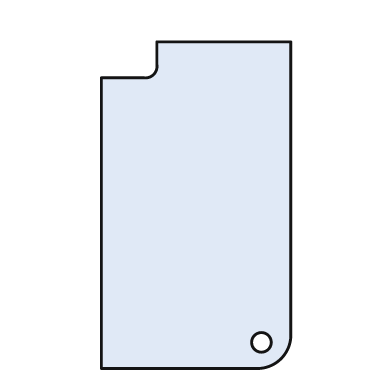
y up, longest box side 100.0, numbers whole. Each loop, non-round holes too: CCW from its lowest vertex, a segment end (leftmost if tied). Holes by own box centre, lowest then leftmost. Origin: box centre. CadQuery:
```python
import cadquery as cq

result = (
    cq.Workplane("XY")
    .moveTo(-29.0, -50.0)
    .lineTo(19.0, -50.0)
    .threePointArc((26.0, -47.0), (29.0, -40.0))
    .lineTo(29.0, 50.0)
    .lineTo(-12.0, 50.0)
    .lineTo(-12.0, 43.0)
    .threePointArc((-13.0, 40.0), (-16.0, 39.0))
    .lineTo(-29.0, 39.0)
    .close()
    .moveTo(20.0, -42.0)
    .circle(3.0)
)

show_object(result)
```